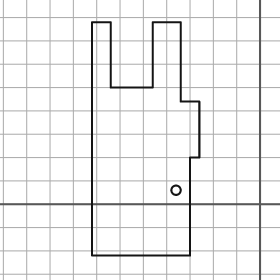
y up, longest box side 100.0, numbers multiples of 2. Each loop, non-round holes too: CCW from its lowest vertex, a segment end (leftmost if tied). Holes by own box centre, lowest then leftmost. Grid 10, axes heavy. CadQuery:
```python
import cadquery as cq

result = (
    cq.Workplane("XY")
    .moveTo(-72.0, -22.0)
    .lineTo(-30.0, -22.0)
    .lineTo(-30.0, 20.0)
    .lineTo(-26.0, 20.0)
    .lineTo(-26.0, 44.0)
    .lineTo(-34.0, 44.0)
    .lineTo(-34.0, 78.0)
    .lineTo(-46.0, 78.0)
    .lineTo(-46.0, 50.0)
    .lineTo(-64.0, 50.0)
    .lineTo(-64.0, 78.0)
    .lineTo(-72.0, 78.0)
    .close()
    .moveTo(-36.0, 6.0)
    .circle(2.0)
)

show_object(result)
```